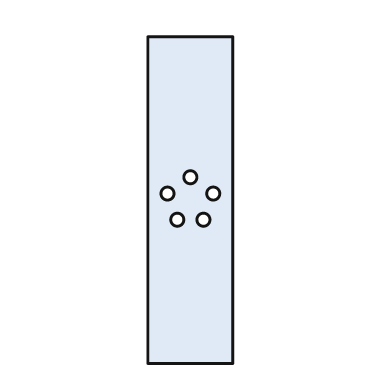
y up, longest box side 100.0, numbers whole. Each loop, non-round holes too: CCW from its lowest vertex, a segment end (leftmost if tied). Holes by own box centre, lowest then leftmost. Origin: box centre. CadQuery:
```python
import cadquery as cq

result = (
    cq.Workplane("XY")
    .moveTo(-13.0, -50.0)
    .lineTo(13.0, -50.0)
    .lineTo(13.0, 50.0)
    .lineTo(-13.0, 50.0)
    .close()
    .moveTo(-4.0, -6.0)
    .circle(2.0)
    .moveTo(4.0, -6.0)
    .circle(2.0)
    .moveTo(-7.0, 2.0)
    .circle(2.0)
    .moveTo(7.0, 2.0)
    .circle(2.0)
    .moveTo(0.0, 7.0)
    .circle(2.0)
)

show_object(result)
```